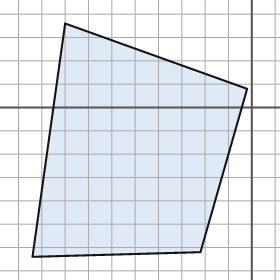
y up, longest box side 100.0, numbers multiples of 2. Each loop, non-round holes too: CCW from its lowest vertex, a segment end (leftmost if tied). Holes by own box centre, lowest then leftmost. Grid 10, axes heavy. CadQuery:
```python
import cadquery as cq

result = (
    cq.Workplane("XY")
    .moveTo(-94.0, -64.0)
    .lineTo(-22.0, -62.0)
    .lineTo(-2.0, 8.0)
    .lineTo(-80.0, 36.0)
    .close()
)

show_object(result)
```